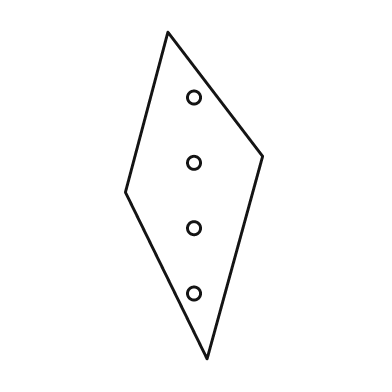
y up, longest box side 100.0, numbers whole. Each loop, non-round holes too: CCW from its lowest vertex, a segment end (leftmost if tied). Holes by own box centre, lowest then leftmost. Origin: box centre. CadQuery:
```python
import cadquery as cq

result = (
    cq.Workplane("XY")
    .moveTo(4.0, -50.0)
    .lineTo(21.0, 12.0)
    .lineTo(-8.0, 50.0)
    .lineTo(-21.0, 1.0)
    .close()
    .moveTo(0.0, -30.0)
    .circle(2.0)
    .moveTo(0.0, -10.0)
    .circle(2.0)
    .moveTo(0.0, 10.0)
    .circle(2.0)
    .moveTo(0.0, 30.0)
    .circle(2.0)
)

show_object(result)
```